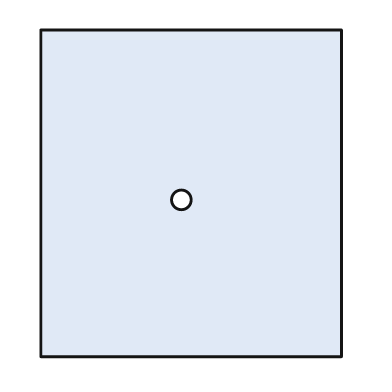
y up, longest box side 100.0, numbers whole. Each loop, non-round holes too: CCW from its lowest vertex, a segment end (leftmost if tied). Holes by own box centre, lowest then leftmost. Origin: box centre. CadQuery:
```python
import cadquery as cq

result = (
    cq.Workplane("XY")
    .moveTo(-46.0, -50.0)
    .lineTo(46.0, -50.0)
    .lineTo(46.0, 50.0)
    .lineTo(-46.0, 50.0)
    .close()
    .moveTo(-3.0, -2.0)
    .circle(3.0)
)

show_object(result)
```